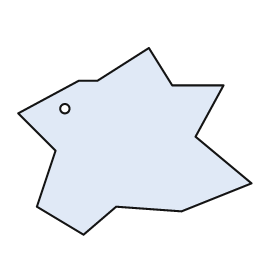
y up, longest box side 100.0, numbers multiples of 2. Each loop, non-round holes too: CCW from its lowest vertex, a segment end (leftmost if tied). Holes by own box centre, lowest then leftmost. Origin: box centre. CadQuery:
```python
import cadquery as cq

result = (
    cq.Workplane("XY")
    .moveTo(-22.0, -40.0)
    .lineTo(-8.0, -28.0)
    .lineTo(20.0, -30.0)
    .lineTo(50.0, -18.0)
    .lineTo(26.0, 2.0)
    .lineTo(38.0, 24.0)
    .lineTo(16.0, 24.0)
    .lineTo(6.0, 40.0)
    .lineTo(-16.0, 26.0)
    .lineTo(-24.0, 26.0)
    .lineTo(-50.0, 12.0)
    .lineTo(-34.0, -4.0)
    .lineTo(-42.0, -28.0)
    .close()
    .moveTo(-30.0, 14.0)
    .circle(2.0)
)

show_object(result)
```